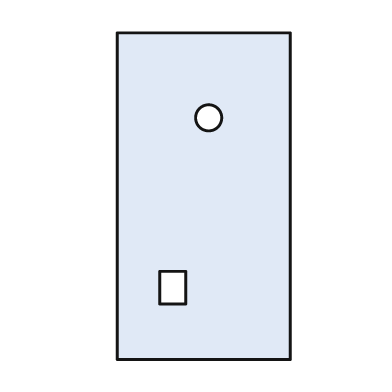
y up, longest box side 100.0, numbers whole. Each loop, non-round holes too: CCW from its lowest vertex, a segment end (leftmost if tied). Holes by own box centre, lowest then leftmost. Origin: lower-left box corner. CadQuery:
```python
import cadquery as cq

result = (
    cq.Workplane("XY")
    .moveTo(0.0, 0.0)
    .lineTo(53.0, 0.0)
    .lineTo(53.0, 100.0)
    .lineTo(0.0, 100.0)
    .close()
    .moveTo(13.0, 17.0)
    .lineTo(21.0, 17.0)
    .lineTo(21.0, 27.0)
    .lineTo(13.0, 27.0)
    .close()
    .moveTo(28.0, 74.0)
    .circle(4.0)
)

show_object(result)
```